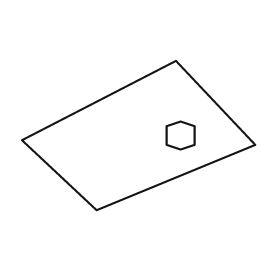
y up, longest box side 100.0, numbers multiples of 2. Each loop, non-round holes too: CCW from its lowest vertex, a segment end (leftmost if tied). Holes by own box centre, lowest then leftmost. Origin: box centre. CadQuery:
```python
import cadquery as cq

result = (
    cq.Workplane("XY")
    .moveTo(-18.0, -32.0)
    .lineTo(50.0, -4.0)
    .lineTo(16.0, 32.0)
    .lineTo(-50.0, -2.0)
    .close()
    .moveTo(18.0, -6.0)
    .lineTo(24.0, -4.0)
    .lineTo(24.0, 4.0)
    .lineTo(18.0, 6.0)
    .lineTo(12.0, 4.0)
    .lineTo(12.0, -4.0)
    .close()
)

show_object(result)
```